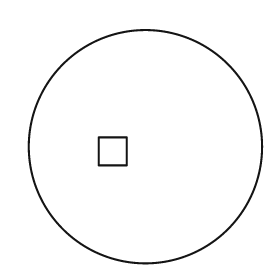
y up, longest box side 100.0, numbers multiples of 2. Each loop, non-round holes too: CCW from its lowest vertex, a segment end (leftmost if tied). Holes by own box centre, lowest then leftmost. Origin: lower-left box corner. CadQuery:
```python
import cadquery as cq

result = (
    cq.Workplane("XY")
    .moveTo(50.0, 50.0)
    .circle(50.0)
    .moveTo(30.0, 42.0)
    .lineTo(42.0, 42.0)
    .lineTo(42.0, 54.0)
    .lineTo(30.0, 54.0)
    .close()
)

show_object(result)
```